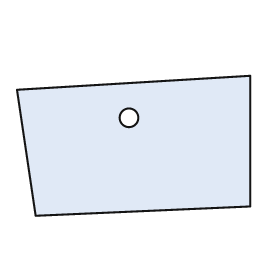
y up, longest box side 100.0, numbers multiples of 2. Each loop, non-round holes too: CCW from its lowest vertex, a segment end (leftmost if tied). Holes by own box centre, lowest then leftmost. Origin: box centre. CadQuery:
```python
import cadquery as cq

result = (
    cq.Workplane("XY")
    .moveTo(-42.0, -30.0)
    .lineTo(50.0, -26.0)
    .lineTo(50.0, 30.0)
    .lineTo(-50.0, 24.0)
    .close()
    .moveTo(-2.0, 12.0)
    .circle(4.0)
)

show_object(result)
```